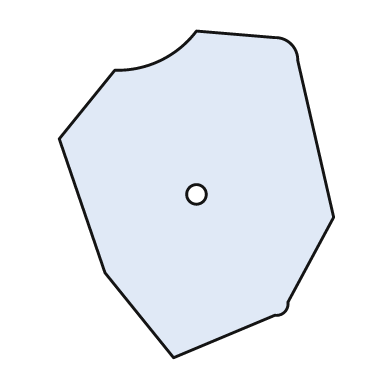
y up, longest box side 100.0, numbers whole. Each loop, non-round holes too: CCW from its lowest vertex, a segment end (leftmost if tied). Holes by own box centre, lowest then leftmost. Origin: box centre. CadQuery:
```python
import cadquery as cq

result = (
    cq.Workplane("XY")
    .moveTo(-7.0, -50.0)
    .lineTo(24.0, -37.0)
    .threePointArc((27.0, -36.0), (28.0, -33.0))
    .lineTo(42.0, -7.0)
    .lineTo(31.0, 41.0)
    .threePointArc((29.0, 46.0), (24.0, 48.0))
    .lineTo(0.0, 50.0)
    .threePointArc((-11.0, 41.0), (-25.0, 38.0))
    .lineTo(-42.0, 17.0)
    .lineTo(-28.0, -24.0)
    .close()
    .moveTo(0.0, 0.0)
    .circle(3.0)
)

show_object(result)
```